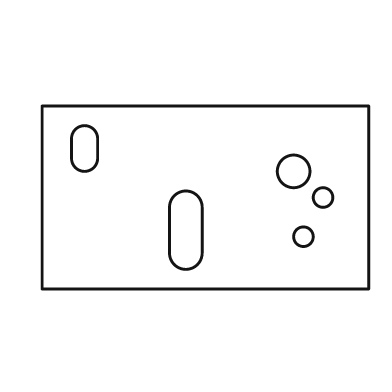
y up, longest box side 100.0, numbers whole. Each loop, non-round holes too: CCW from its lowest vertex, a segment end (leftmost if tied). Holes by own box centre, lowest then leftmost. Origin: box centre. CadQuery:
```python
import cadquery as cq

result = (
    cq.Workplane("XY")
    .moveTo(-50.0, -28.0)
    .lineTo(50.0, -28.0)
    .lineTo(50.0, 28.0)
    .lineTo(-50.0, 28.0)
    .close()
    .moveTo(30.0, -12.0)
    .circle(3.0)
    .moveTo(-11.0, -17.0)
    .threePointArc((-6.0, -22.0), (-1.0, -17.0))
    .lineTo(-1.0, -3.0)
    .threePointArc((-6.0, 2.0), (-11.0, -3.0))
    .close()
    .moveTo(36.0, 0.0)
    .circle(3.0)
    .moveTo(27.0, 8.0)
    .circle(5.0)
    .moveTo(-41.0, 12.0)
    .threePointArc((-37.0, 8.0), (-33.0, 12.0))
    .lineTo(-33.0, 18.0)
    .threePointArc((-37.0, 22.0), (-41.0, 18.0))
    .close()
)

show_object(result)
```